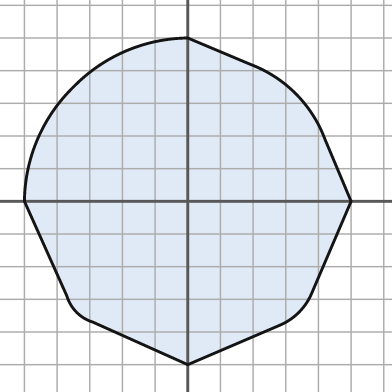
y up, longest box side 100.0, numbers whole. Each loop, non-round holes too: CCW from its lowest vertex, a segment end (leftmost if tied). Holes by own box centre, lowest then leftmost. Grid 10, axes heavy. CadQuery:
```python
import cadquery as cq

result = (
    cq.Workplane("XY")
    .moveTo(0.0, -50.0)
    .lineTo(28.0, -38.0)
    .threePointArc((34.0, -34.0), (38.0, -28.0))
    .lineTo(50.0, 0.0)
    .lineTo(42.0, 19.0)
    .threePointArc((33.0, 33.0), (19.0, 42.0))
    .lineTo(0.0, 50.0)
    .threePointArc((-19.0, 46.0), (-35.0, 35.0))
    .threePointArc((-46.0, 19.0), (-50.0, 0.0))
    .lineTo(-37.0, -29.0)
    .threePointArc((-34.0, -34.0), (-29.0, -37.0))
    .close()
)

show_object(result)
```